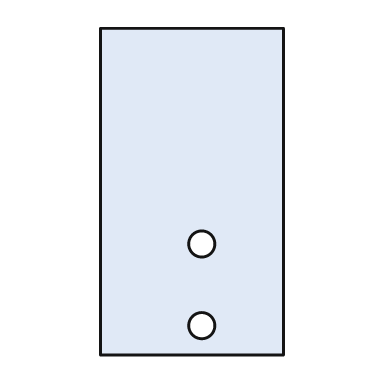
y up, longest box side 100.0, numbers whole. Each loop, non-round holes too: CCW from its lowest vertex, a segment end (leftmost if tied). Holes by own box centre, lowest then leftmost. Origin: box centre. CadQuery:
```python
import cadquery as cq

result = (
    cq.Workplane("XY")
    .moveTo(-28.0, -50.0)
    .lineTo(28.0, -50.0)
    .lineTo(28.0, 50.0)
    .lineTo(-28.0, 50.0)
    .close()
    .moveTo(3.0, -41.0)
    .circle(4.0)
    .moveTo(3.0, -16.0)
    .circle(4.0)
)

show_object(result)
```